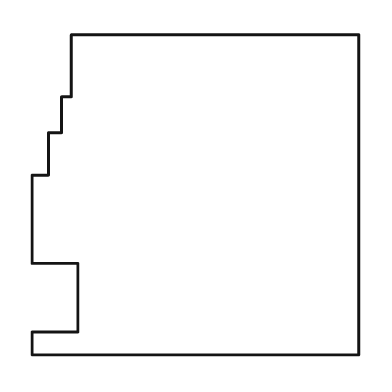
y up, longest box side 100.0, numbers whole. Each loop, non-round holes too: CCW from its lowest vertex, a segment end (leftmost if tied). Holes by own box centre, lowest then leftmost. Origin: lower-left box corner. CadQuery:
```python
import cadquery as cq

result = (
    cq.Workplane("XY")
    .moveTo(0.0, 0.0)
    .lineTo(100.0, 0.0)
    .lineTo(100.0, 98.0)
    .lineTo(12.0, 98.0)
    .lineTo(12.0, 79.0)
    .lineTo(9.0, 79.0)
    .lineTo(9.0, 68.0)
    .lineTo(5.0, 68.0)
    .lineTo(5.0, 55.0)
    .lineTo(0.0, 55.0)
    .lineTo(0.0, 28.0)
    .lineTo(14.0, 28.0)
    .lineTo(14.0, 7.0)
    .lineTo(0.0, 7.0)
    .close()
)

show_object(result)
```